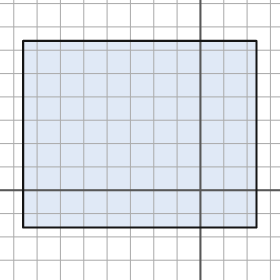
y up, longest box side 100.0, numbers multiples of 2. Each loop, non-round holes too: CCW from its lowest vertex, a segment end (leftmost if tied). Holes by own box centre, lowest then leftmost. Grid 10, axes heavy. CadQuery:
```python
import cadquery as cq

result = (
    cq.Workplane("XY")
    .moveTo(-76.0, -16.0)
    .lineTo(24.0, -16.0)
    .lineTo(24.0, 64.0)
    .lineTo(-76.0, 64.0)
    .close()
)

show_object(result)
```